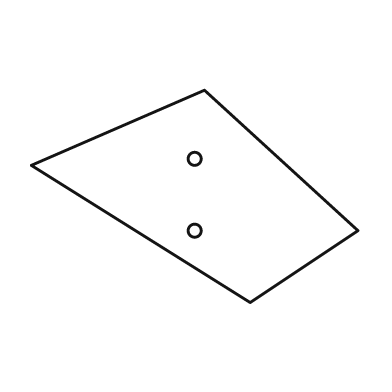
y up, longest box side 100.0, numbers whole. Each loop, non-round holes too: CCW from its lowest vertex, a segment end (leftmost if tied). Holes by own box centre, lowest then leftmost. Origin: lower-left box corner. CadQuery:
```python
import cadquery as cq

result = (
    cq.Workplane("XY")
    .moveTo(67.0, 0.0)
    .lineTo(100.0, 22.0)
    .lineTo(53.0, 65.0)
    .lineTo(0.0, 42.0)
    .close()
    .moveTo(50.0, 22.0)
    .circle(2.0)
    .moveTo(50.0, 44.0)
    .circle(2.0)
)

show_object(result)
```